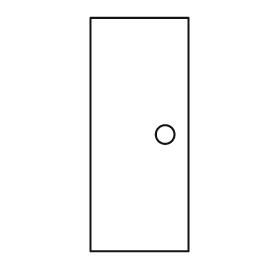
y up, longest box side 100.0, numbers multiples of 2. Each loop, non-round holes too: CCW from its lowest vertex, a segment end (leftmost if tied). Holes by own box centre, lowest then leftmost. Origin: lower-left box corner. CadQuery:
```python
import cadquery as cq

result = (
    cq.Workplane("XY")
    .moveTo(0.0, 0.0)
    .lineTo(42.0, 0.0)
    .lineTo(42.0, 100.0)
    .lineTo(0.0, 100.0)
    .close()
    .moveTo(32.0, 50.0)
    .circle(4.0)
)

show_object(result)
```